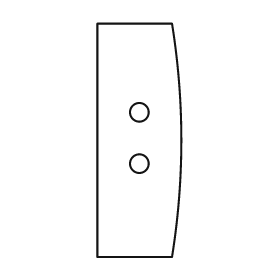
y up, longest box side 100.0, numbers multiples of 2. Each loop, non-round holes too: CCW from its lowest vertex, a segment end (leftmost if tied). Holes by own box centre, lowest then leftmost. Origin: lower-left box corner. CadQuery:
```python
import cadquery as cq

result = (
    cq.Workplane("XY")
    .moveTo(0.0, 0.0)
    .lineTo(32.0, 0.0)
    .threePointArc((36.0, 50.0), (32.0, 100.0))
    .lineTo(0.0, 100.0)
    .close()
    .moveTo(18.0, 40.0)
    .circle(4.0)
    .moveTo(18.0, 62.0)
    .circle(4.0)
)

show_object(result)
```